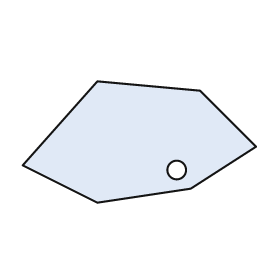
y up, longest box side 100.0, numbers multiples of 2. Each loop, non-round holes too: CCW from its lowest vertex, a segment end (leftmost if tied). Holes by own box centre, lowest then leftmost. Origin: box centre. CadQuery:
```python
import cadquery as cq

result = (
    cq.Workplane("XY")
    .moveTo(-18.0, -26.0)
    .lineTo(22.0, -20.0)
    .lineTo(50.0, -2.0)
    .lineTo(26.0, 22.0)
    .lineTo(-18.0, 26.0)
    .lineTo(-50.0, -10.0)
    .close()
    .moveTo(16.0, -12.0)
    .circle(4.0)
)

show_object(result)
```